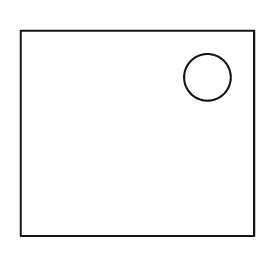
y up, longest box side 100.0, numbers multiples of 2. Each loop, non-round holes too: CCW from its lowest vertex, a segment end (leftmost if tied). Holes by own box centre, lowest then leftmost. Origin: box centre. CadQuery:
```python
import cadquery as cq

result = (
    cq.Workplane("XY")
    .moveTo(-50.0, -44.0)
    .lineTo(50.0, -44.0)
    .lineTo(50.0, 44.0)
    .lineTo(-50.0, 44.0)
    .close()
    .moveTo(30.0, 24.0)
    .circle(10.0)
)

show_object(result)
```